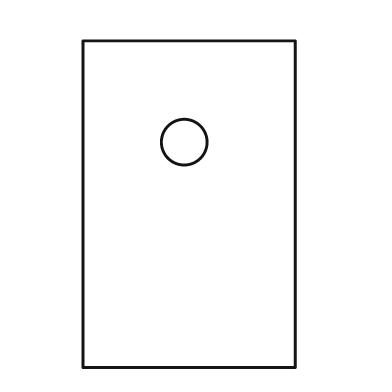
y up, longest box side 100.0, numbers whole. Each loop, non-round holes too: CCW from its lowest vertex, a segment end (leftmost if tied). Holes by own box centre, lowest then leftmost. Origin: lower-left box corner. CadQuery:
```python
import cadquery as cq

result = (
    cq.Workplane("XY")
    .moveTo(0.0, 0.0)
    .lineTo(65.0, 0.0)
    .lineTo(65.0, 100.0)
    .lineTo(0.0, 100.0)
    .close()
    .moveTo(31.0, 69.0)
    .circle(7.0)
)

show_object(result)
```